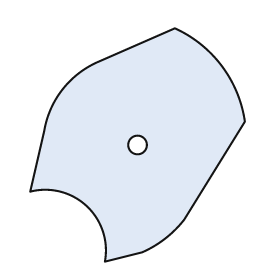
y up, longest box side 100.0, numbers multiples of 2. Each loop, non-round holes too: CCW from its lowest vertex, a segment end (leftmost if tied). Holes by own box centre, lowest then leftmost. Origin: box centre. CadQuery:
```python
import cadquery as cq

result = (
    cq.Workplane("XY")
    .moveTo(-14.0, -50.0)
    .lineTo(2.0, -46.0)
    .threePointArc((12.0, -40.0), (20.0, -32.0))
    .lineTo(46.0, 10.0)
    .threePointArc((36.0, 34.0), (16.0, 50.0))
    .lineTo(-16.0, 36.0)
    .threePointArc((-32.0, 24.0), (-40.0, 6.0))
    .lineTo(-46.0, -20.0)
    .threePointArc((-22.0, -26.0), (-14.0, -50.0))
    .close()
    .moveTo(0.0, 0.0)
    .circle(4.0)
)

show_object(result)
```